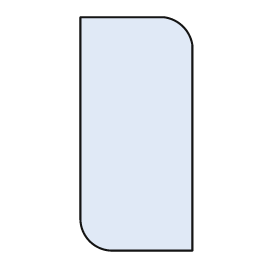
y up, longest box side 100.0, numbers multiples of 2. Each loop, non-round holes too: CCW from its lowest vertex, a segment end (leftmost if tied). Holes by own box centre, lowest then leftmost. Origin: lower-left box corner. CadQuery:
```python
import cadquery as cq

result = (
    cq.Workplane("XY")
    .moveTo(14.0, 0.0)
    .lineTo(48.0, 0.0)
    .lineTo(48.0, 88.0)
    .threePointArc((44.0, 96.0), (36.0, 100.0))
    .lineTo(0.0, 100.0)
    .lineTo(0.0, 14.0)
    .threePointArc((4.0, 4.0), (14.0, 0.0))
    .close()
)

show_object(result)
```